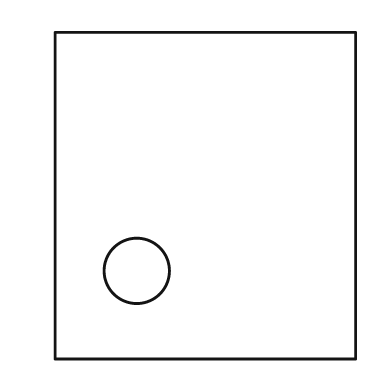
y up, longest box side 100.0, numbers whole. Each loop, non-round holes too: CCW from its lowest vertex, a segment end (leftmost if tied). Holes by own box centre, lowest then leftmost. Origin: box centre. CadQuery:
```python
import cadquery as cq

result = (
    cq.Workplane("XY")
    .moveTo(-46.0, -50.0)
    .lineTo(46.0, -50.0)
    .lineTo(46.0, 50.0)
    .lineTo(-46.0, 50.0)
    .close()
    .moveTo(-21.0, -23.0)
    .circle(10.0)
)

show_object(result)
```